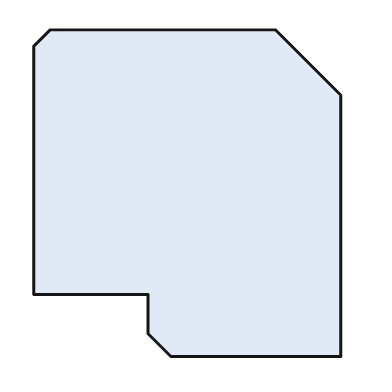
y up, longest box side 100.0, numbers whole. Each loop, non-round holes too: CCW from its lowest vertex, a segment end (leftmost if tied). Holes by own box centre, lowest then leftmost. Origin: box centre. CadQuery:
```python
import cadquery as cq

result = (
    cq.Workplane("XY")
    .moveTo(-5.0, -50.0)
    .lineTo(47.0, -50.0)
    .lineTo(47.0, 30.0)
    .lineTo(27.0, 50.0)
    .lineTo(-42.0, 50.0)
    .lineTo(-47.0, 45.0)
    .lineTo(-47.0, -31.0)
    .lineTo(-12.0, -31.0)
    .lineTo(-12.0, -43.0)
    .close()
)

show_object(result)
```